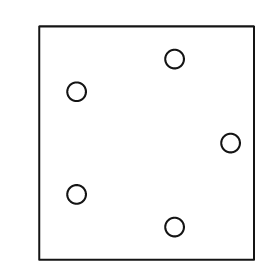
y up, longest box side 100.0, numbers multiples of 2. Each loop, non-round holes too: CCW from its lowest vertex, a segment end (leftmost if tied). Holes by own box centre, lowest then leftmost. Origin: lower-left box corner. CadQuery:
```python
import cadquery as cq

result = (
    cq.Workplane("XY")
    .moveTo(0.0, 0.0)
    .lineTo(92.0, 0.0)
    .lineTo(92.0, 100.0)
    .lineTo(0.0, 100.0)
    .close()
    .moveTo(58.0, 14.0)
    .circle(4.0)
    .moveTo(16.0, 28.0)
    .circle(4.0)
    .moveTo(82.0, 50.0)
    .circle(4.0)
    .moveTo(16.0, 72.0)
    .circle(4.0)
    .moveTo(58.0, 86.0)
    .circle(4.0)
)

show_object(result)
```